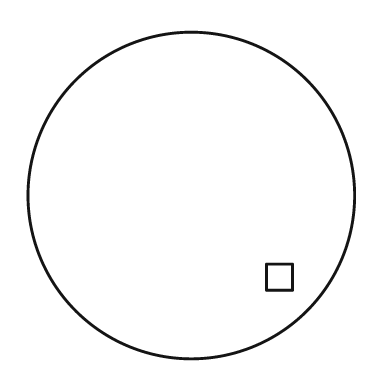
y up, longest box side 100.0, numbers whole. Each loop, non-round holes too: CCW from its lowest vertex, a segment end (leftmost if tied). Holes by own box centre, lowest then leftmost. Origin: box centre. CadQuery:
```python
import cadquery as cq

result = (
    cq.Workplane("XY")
    .moveTo(0.0, 0.0)
    .circle(50.0)
    .moveTo(23.0, -29.0)
    .lineTo(31.0, -29.0)
    .lineTo(31.0, -21.0)
    .lineTo(23.0, -21.0)
    .close()
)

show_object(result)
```